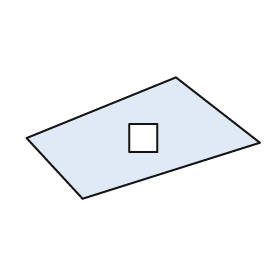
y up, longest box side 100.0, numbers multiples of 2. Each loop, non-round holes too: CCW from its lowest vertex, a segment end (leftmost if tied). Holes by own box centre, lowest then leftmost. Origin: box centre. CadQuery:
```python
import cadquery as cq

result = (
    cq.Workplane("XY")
    .moveTo(-26.0, -26.0)
    .lineTo(50.0, -2.0)
    .lineTo(14.0, 26.0)
    .lineTo(-50.0, 0.0)
    .close()
    .moveTo(-6.0, -6.0)
    .lineTo(6.0, -6.0)
    .lineTo(6.0, 6.0)
    .lineTo(-6.0, 6.0)
    .close()
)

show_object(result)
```